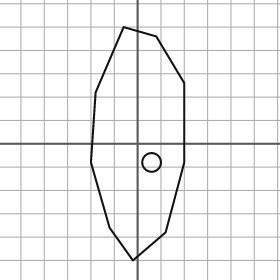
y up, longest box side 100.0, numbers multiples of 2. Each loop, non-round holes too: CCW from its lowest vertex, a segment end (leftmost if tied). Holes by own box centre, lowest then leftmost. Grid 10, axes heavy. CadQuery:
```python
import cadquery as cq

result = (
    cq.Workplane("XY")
    .moveTo(-2.0, -50.0)
    .lineTo(12.0, -38.0)
    .lineTo(20.0, -8.0)
    .lineTo(20.0, 26.0)
    .lineTo(8.0, 46.0)
    .lineTo(-6.0, 50.0)
    .lineTo(-18.0, 22.0)
    .lineTo(-20.0, -8.0)
    .lineTo(-12.0, -36.0)
    .close()
    .moveTo(6.0, -8.0)
    .circle(4.0)
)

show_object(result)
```